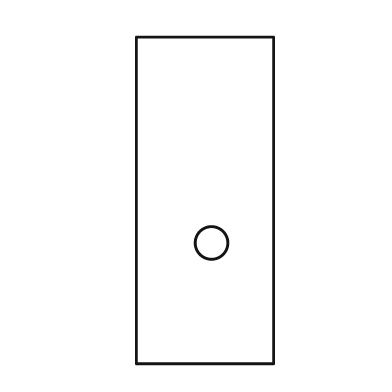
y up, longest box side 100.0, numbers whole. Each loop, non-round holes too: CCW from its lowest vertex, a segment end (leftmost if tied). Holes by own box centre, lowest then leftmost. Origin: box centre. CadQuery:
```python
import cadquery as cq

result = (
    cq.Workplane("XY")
    .moveTo(-21.0, -50.0)
    .lineTo(21.0, -50.0)
    .lineTo(21.0, 50.0)
    .lineTo(-21.0, 50.0)
    .close()
    .moveTo(2.0, -13.0)
    .circle(5.0)
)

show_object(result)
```